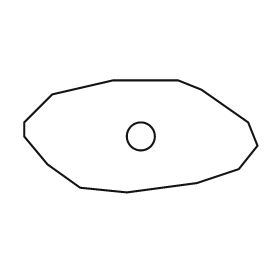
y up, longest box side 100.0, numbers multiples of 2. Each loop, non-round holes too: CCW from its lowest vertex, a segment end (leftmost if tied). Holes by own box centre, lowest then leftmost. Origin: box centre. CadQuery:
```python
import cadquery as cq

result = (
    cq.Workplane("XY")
    .moveTo(-6.0, -24.0)
    .lineTo(24.0, -20.0)
    .lineTo(42.0, -14.0)
    .lineTo(50.0, -4.0)
    .lineTo(46.0, 6.0)
    .lineTo(26.0, 20.0)
    .lineTo(16.0, 24.0)
    .lineTo(-12.0, 24.0)
    .lineTo(-38.0, 18.0)
    .lineTo(-50.0, 6.0)
    .lineTo(-50.0, 0.0)
    .lineTo(-40.0, -12.0)
    .lineTo(-26.0, -22.0)
    .close()
    .moveTo(0.0, 0.0)
    .circle(6.0)
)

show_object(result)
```